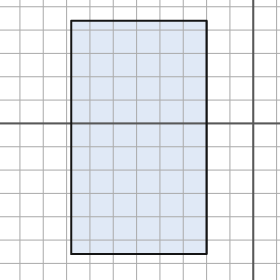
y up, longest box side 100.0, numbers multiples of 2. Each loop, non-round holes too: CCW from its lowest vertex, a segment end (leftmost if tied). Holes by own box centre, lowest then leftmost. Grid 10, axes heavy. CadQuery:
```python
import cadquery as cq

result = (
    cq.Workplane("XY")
    .moveTo(-78.0, -56.0)
    .lineTo(-20.0, -56.0)
    .lineTo(-20.0, 44.0)
    .lineTo(-78.0, 44.0)
    .close()
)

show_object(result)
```